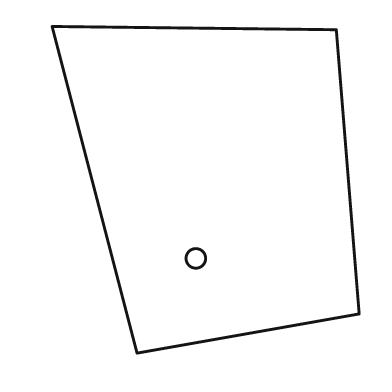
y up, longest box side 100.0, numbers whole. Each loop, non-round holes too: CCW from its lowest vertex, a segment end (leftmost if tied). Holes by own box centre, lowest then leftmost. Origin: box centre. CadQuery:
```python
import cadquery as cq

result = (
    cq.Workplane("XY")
    .moveTo(-21.0, -50.0)
    .lineTo(47.0, -38.0)
    .lineTo(40.0, 49.0)
    .lineTo(-47.0, 50.0)
    .close()
    .moveTo(-3.0, -21.0)
    .circle(3.0)
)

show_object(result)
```